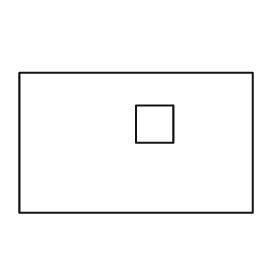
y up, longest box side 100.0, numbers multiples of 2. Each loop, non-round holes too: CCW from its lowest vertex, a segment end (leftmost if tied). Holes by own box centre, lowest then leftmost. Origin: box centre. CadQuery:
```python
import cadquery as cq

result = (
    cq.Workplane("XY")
    .moveTo(-50.0, -30.0)
    .lineTo(50.0, -30.0)
    .lineTo(50.0, 30.0)
    .lineTo(-50.0, 30.0)
    .close()
    .moveTo(0.0, 0.0)
    .lineTo(16.0, 0.0)
    .lineTo(16.0, 16.0)
    .lineTo(0.0, 16.0)
    .close()
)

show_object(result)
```